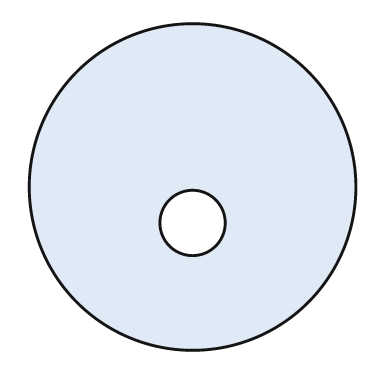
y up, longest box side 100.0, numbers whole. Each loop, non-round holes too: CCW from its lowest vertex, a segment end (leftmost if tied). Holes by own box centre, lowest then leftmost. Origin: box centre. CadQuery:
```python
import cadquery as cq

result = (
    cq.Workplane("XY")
    .moveTo(0.0, 0.0)
    .circle(50.0)
    .moveTo(0.0, -11.0)
    .circle(10.0)
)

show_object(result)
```